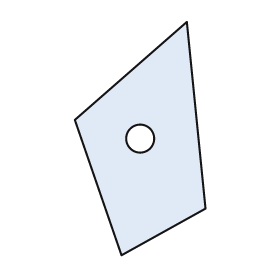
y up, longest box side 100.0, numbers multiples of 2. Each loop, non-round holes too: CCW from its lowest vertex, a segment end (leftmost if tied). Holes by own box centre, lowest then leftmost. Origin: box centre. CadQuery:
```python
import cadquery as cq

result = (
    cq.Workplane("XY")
    .moveTo(-8.0, -50.0)
    .lineTo(28.0, -30.0)
    .lineTo(20.0, 50.0)
    .lineTo(-28.0, 8.0)
    .close()
    .moveTo(0.0, 0.0)
    .circle(6.0)
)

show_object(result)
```